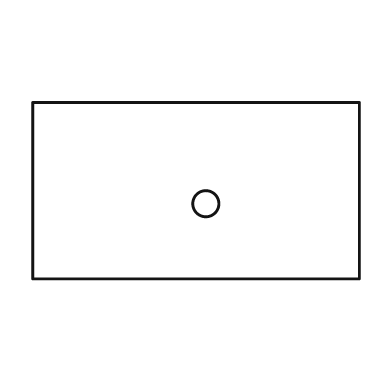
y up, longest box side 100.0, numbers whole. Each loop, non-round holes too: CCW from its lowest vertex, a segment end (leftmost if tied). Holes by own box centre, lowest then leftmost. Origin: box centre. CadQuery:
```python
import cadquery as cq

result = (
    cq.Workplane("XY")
    .moveTo(-50.0, -27.0)
    .lineTo(50.0, -27.0)
    .lineTo(50.0, 27.0)
    .lineTo(-50.0, 27.0)
    .close()
    .moveTo(3.0, -4.0)
    .circle(4.0)
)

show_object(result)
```